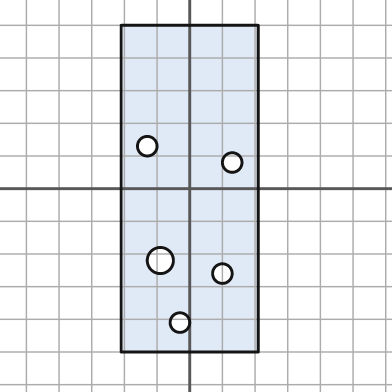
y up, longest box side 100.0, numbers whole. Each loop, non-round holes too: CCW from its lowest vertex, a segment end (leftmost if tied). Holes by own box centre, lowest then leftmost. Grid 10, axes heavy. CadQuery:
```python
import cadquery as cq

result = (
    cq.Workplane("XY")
    .moveTo(-21.0, -50.0)
    .lineTo(21.0, -50.0)
    .lineTo(21.0, 50.0)
    .lineTo(-21.0, 50.0)
    .close()
    .moveTo(-3.0, -41.0)
    .circle(3.0)
    .moveTo(10.0, -26.0)
    .circle(3.0)
    .moveTo(-9.0, -22.0)
    .circle(4.0)
    .moveTo(13.0, 8.0)
    .circle(3.0)
    .moveTo(-13.0, 13.0)
    .circle(3.0)
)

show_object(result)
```